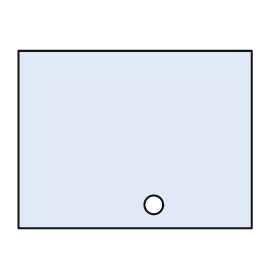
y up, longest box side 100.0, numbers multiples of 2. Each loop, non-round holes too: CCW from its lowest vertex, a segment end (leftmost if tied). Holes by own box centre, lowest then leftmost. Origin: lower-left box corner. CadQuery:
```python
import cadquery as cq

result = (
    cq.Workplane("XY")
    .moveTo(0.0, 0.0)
    .lineTo(100.0, 0.0)
    .lineTo(100.0, 76.0)
    .lineTo(0.0, 76.0)
    .close()
    .moveTo(58.0, 10.0)
    .circle(4.0)
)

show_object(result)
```